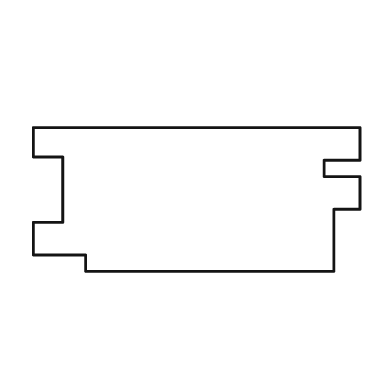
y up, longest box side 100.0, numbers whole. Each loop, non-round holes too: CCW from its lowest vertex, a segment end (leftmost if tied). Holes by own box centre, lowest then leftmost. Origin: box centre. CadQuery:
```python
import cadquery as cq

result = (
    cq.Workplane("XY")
    .moveTo(-34.0, -22.0)
    .lineTo(42.0, -22.0)
    .lineTo(42.0, -3.0)
    .lineTo(50.0, -3.0)
    .lineTo(50.0, 7.0)
    .lineTo(39.0, 7.0)
    .lineTo(39.0, 12.0)
    .lineTo(50.0, 12.0)
    .lineTo(50.0, 22.0)
    .lineTo(-50.0, 22.0)
    .lineTo(-50.0, 13.0)
    .lineTo(-41.0, 13.0)
    .lineTo(-41.0, -7.0)
    .lineTo(-50.0, -7.0)
    .lineTo(-50.0, -17.0)
    .lineTo(-34.0, -17.0)
    .close()
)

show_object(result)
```